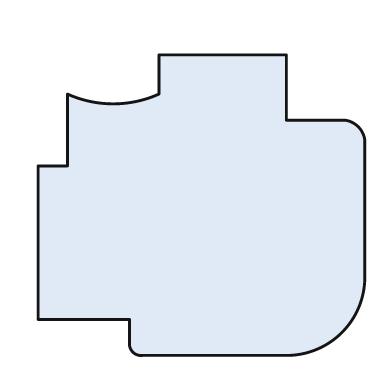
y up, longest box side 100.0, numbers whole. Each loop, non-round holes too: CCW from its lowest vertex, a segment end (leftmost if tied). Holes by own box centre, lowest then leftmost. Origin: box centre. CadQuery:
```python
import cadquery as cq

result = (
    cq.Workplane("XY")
    .moveTo(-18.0, -46.0)
    .lineTo(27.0, -46.0)
    .threePointArc((43.0, -39.0), (50.0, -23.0))
    .lineTo(50.0, 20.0)
    .threePointArc((48.0, 24.0), (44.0, 26.0))
    .lineTo(26.0, 26.0)
    .lineTo(26.0, 46.0)
    .lineTo(-13.0, 46.0)
    .lineTo(-13.0, 34.0)
    .threePointArc((-27.0, 31.0), (-41.0, 34.0))
    .lineTo(-41.0, 12.0)
    .lineTo(-50.0, 12.0)
    .lineTo(-50.0, -35.0)
    .lineTo(-22.0, -35.0)
    .lineTo(-22.0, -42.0)
    .threePointArc((-21.0, -45.0), (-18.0, -46.0))
    .close()
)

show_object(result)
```